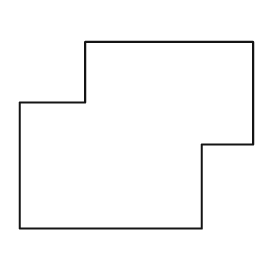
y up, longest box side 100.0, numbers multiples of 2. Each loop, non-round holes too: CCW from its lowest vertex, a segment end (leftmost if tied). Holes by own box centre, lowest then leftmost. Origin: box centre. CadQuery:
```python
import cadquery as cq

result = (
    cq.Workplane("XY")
    .moveTo(-50.0, -40.0)
    .lineTo(28.0, -40.0)
    .lineTo(28.0, -4.0)
    .lineTo(50.0, -4.0)
    .lineTo(50.0, 40.0)
    .lineTo(-22.0, 40.0)
    .lineTo(-22.0, 14.0)
    .lineTo(-50.0, 14.0)
    .close()
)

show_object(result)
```